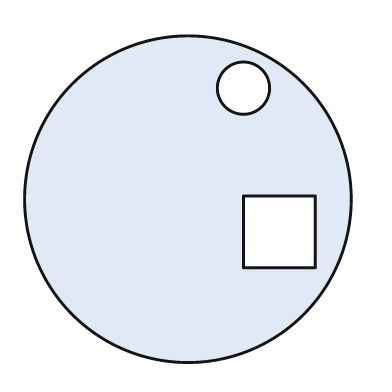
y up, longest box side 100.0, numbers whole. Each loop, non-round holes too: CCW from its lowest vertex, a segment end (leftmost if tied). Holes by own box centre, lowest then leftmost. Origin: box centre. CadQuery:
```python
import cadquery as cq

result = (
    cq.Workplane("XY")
    .moveTo(0.0, 0.0)
    .circle(50.0)
    .moveTo(17.0, -21.0)
    .lineTo(39.0, -21.0)
    .lineTo(39.0, 1.0)
    .lineTo(17.0, 1.0)
    .close()
    .moveTo(17.0, 34.0)
    .circle(8.0)
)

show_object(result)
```